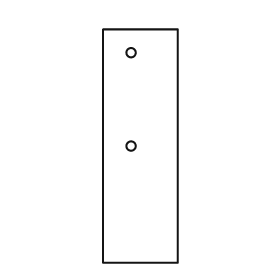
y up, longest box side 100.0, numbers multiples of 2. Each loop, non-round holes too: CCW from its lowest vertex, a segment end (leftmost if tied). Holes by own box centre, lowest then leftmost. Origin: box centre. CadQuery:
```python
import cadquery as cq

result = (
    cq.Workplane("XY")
    .moveTo(-16.0, -50.0)
    .lineTo(16.0, -50.0)
    .lineTo(16.0, 50.0)
    .lineTo(-16.0, 50.0)
    .close()
    .moveTo(-4.0, 0.0)
    .circle(2.0)
    .moveTo(-4.0, 40.0)
    .circle(2.0)
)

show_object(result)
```